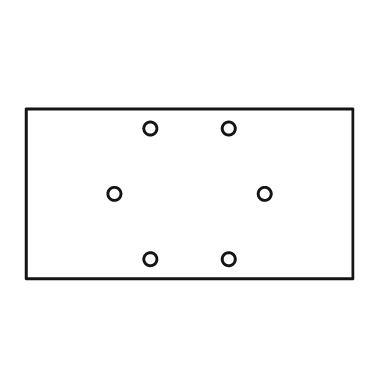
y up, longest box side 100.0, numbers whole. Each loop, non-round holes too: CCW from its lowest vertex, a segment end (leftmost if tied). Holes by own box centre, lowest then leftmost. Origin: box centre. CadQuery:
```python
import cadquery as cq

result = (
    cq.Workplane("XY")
    .moveTo(-50.0, -26.0)
    .lineTo(50.0, -26.0)
    .lineTo(50.0, 26.0)
    .lineTo(-50.0, 26.0)
    .close()
    .moveTo(-12.0, -20.0)
    .circle(2.0)
    .moveTo(12.0, -20.0)
    .circle(2.0)
    .moveTo(-23.0, 0.0)
    .circle(2.0)
    .moveTo(23.0, 0.0)
    .circle(2.0)
    .moveTo(-12.0, 20.0)
    .circle(2.0)
    .moveTo(12.0, 20.0)
    .circle(2.0)
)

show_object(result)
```